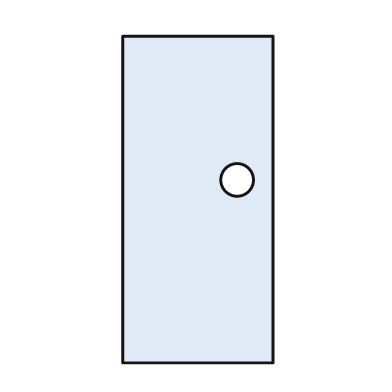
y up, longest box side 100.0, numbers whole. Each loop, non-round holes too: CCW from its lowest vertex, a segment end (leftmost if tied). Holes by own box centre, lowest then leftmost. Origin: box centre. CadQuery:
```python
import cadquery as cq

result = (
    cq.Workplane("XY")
    .moveTo(-23.0, -50.0)
    .lineTo(23.0, -50.0)
    .lineTo(23.0, 50.0)
    .lineTo(-23.0, 50.0)
    .close()
    .moveTo(12.0, 6.0)
    .circle(5.0)
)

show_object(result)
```